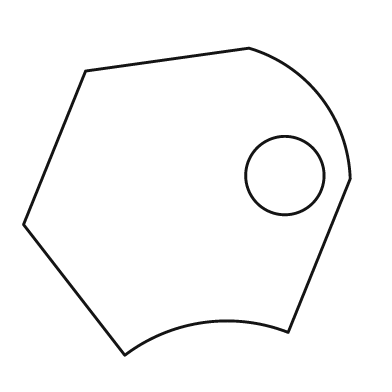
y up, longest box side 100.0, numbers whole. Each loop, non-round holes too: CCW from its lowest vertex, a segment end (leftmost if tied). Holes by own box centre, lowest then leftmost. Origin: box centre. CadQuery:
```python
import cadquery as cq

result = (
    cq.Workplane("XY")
    .moveTo(-19.0, -47.0)
    .threePointArc((5.0, -37.0), (31.0, -40.0))
    .lineTo(50.0, 7.0)
    .threePointArc((41.0, 32.0), (19.0, 47.0))
    .lineTo(-31.0, 40.0)
    .lineTo(-50.0, -7.0)
    .close()
    .moveTo(30.0, 8.0)
    .circle(12.0)
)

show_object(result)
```